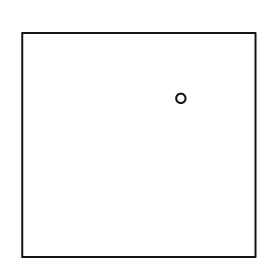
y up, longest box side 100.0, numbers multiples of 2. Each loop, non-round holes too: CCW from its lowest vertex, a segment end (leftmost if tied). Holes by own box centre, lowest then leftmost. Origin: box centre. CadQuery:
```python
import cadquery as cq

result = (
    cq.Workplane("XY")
    .moveTo(-50.0, -48.0)
    .lineTo(50.0, -48.0)
    .lineTo(50.0, 48.0)
    .lineTo(-50.0, 48.0)
    .close()
    .moveTo(18.0, 20.0)
    .circle(2.0)
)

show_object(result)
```